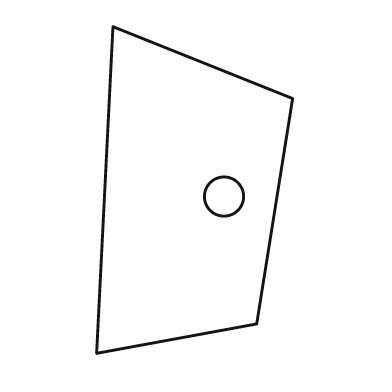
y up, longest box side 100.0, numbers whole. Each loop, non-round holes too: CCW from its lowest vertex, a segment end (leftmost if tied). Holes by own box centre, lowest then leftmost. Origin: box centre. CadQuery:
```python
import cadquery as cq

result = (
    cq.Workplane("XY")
    .moveTo(-30.0, -50.0)
    .lineTo(19.0, -41.0)
    .lineTo(30.0, 28.0)
    .lineTo(-25.0, 50.0)
    .close()
    .moveTo(9.0, -2.0)
    .circle(6.0)
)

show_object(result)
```